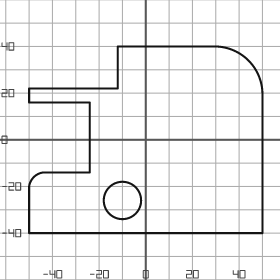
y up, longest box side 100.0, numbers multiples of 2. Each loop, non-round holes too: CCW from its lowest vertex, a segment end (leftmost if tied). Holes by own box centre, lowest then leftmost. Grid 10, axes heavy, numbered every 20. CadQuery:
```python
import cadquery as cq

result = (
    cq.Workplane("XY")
    .moveTo(-50.0, -40.0)
    .lineTo(50.0, -40.0)
    .lineTo(50.0, 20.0)
    .threePointArc((44.0, 34.0), (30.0, 40.0))
    .lineTo(-12.0, 40.0)
    .lineTo(-12.0, 22.0)
    .lineTo(-50.0, 22.0)
    .lineTo(-50.0, 16.0)
    .lineTo(-24.0, 16.0)
    .lineTo(-24.0, -14.0)
    .lineTo(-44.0, -14.0)
    .threePointArc((-48.0, -16.0), (-50.0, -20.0))
    .close()
    .moveTo(-10.0, -26.0)
    .circle(8.0)
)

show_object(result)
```